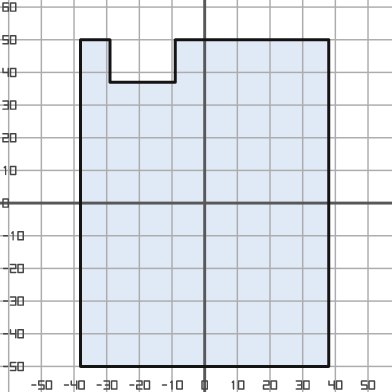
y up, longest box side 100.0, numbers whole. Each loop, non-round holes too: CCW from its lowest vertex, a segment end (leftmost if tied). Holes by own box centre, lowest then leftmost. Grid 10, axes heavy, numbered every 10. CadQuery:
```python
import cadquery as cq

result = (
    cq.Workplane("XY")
    .moveTo(-38.0, -50.0)
    .lineTo(38.0, -50.0)
    .lineTo(38.0, 50.0)
    .lineTo(-9.0, 50.0)
    .lineTo(-9.0, 37.0)
    .lineTo(-29.0, 37.0)
    .lineTo(-29.0, 50.0)
    .lineTo(-38.0, 50.0)
    .close()
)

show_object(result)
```